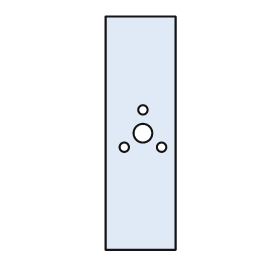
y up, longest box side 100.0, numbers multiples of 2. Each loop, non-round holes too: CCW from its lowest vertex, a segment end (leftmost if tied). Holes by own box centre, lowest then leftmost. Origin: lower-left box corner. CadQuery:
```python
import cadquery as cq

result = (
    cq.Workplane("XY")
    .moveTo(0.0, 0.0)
    .lineTo(30.0, 0.0)
    .lineTo(30.0, 100.0)
    .lineTo(0.0, 100.0)
    .close()
    .moveTo(8.0, 44.0)
    .circle(2.0)
    .moveTo(24.0, 44.0)
    .circle(2.0)
    .moveTo(16.0, 50.0)
    .circle(4.0)
    .moveTo(16.0, 60.0)
    .circle(2.0)
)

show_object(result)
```